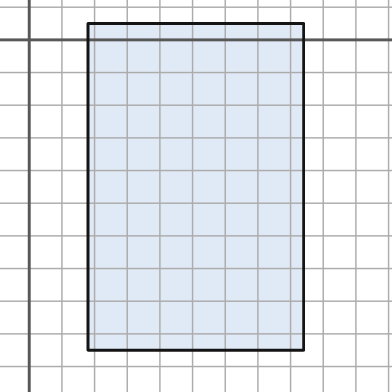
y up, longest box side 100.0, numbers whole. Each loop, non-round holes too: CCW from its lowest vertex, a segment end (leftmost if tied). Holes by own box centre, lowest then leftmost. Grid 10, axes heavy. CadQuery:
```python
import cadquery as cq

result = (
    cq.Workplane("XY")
    .moveTo(18.0, -95.0)
    .lineTo(84.0, -95.0)
    .lineTo(84.0, 5.0)
    .lineTo(18.0, 5.0)
    .close()
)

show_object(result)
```